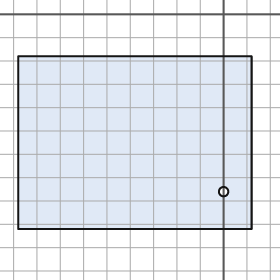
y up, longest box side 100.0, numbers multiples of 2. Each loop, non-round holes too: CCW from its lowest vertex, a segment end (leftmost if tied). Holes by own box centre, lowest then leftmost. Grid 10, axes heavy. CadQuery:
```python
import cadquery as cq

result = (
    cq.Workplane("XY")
    .moveTo(-88.0, -92.0)
    .lineTo(12.0, -92.0)
    .lineTo(12.0, -18.0)
    .lineTo(-88.0, -18.0)
    .close()
    .moveTo(0.0, -76.0)
    .circle(2.0)
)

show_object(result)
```